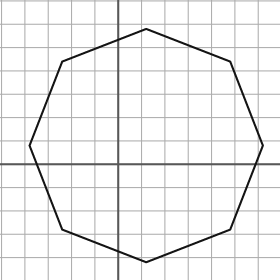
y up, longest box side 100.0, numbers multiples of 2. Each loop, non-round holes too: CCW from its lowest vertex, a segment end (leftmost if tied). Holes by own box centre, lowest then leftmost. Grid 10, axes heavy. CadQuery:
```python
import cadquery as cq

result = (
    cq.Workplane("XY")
    .moveTo(12.0, -42.0)
    .lineTo(48.0, -28.0)
    .lineTo(62.0, 8.0)
    .lineTo(48.0, 44.0)
    .lineTo(12.0, 58.0)
    .lineTo(-24.0, 44.0)
    .lineTo(-38.0, 8.0)
    .lineTo(-24.0, -28.0)
    .close()
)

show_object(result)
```